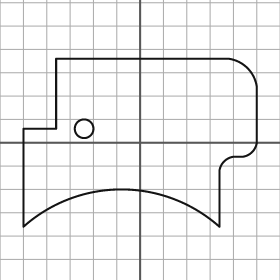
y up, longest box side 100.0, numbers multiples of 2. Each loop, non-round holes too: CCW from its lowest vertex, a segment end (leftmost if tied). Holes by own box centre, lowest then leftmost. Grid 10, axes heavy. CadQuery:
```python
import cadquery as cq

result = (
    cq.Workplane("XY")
    .moveTo(-50.0, -36.0)
    .threePointArc((-8.0, -20.0), (34.0, -36.0))
    .lineTo(34.0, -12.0)
    .threePointArc((36.0, -8.0), (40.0, -6.0))
    .lineTo(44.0, -6.0)
    .threePointArc((48.0, -4.0), (50.0, 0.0))
    .lineTo(50.0, 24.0)
    .threePointArc((46.0, 32.0), (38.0, 36.0))
    .lineTo(-36.0, 36.0)
    .lineTo(-36.0, 6.0)
    .lineTo(-50.0, 6.0)
    .close()
    .moveTo(-24.0, 6.0)
    .circle(4.0)
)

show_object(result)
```